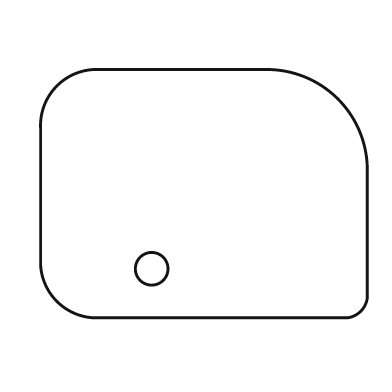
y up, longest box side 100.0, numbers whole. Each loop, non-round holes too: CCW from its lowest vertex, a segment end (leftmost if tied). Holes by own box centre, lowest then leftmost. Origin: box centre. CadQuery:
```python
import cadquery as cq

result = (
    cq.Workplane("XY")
    .moveTo(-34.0, -38.0)
    .lineTo(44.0, -38.0)
    .threePointArc((48.0, -36.0), (50.0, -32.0))
    .lineTo(50.0, 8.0)
    .threePointArc((41.0, 29.0), (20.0, 38.0))
    .lineTo(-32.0, 38.0)
    .threePointArc((-45.0, 33.0), (-50.0, 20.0))
    .lineTo(-50.0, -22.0)
    .threePointArc((-45.0, -33.0), (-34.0, -38.0))
    .close()
    .moveTo(-16.0, -23.0)
    .circle(5.0)
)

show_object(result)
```